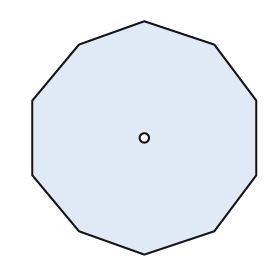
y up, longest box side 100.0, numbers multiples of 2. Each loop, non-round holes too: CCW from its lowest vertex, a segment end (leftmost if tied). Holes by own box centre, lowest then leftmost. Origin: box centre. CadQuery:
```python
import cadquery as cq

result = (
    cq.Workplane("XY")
    .moveTo(0.0, -50.0)
    .lineTo(30.0, -40.0)
    .lineTo(48.0, -16.0)
    .lineTo(48.0, 16.0)
    .lineTo(30.0, 40.0)
    .lineTo(0.0, 50.0)
    .lineTo(-28.0, 40.0)
    .lineTo(-48.0, 16.0)
    .lineTo(-48.0, -16.0)
    .lineTo(-28.0, -40.0)
    .close()
    .moveTo(0.0, 0.0)
    .circle(2.0)
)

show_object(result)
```